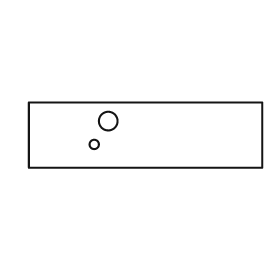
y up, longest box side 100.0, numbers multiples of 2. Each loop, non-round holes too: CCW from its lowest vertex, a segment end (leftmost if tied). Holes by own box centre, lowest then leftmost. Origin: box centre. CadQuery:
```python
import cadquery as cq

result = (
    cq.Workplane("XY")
    .moveTo(-50.0, -14.0)
    .lineTo(50.0, -14.0)
    .lineTo(50.0, 14.0)
    .lineTo(-50.0, 14.0)
    .close()
    .moveTo(-22.0, -4.0)
    .circle(2.0)
    .moveTo(-16.0, 6.0)
    .circle(4.0)
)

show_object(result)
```